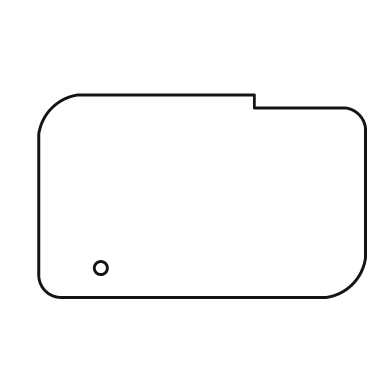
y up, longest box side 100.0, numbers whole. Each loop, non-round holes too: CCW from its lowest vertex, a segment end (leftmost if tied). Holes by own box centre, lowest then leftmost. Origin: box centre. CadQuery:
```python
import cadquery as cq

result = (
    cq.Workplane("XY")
    .moveTo(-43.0, -31.0)
    .lineTo(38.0, -31.0)
    .threePointArc((46.0, -27.0), (50.0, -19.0))
    .lineTo(50.0, 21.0)
    .threePointArc((48.0, 25.0), (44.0, 27.0))
    .lineTo(16.0, 27.0)
    .lineTo(16.0, 31.0)
    .lineTo(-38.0, 31.0)
    .threePointArc((-46.0, 27.0), (-50.0, 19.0))
    .lineTo(-50.0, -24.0)
    .threePointArc((-48.0, -29.0), (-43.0, -31.0))
    .close()
    .moveTo(-31.0, -22.0)
    .circle(2.0)
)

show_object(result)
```